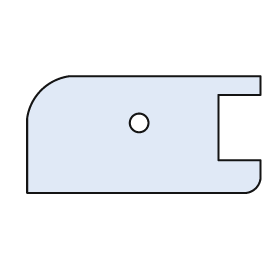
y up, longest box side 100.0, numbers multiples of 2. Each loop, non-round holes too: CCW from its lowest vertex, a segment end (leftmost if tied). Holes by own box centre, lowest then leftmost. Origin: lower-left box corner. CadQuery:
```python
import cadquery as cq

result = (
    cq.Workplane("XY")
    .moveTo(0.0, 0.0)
    .lineTo(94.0, 0.0)
    .threePointArc((98.0, 2.0), (100.0, 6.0))
    .lineTo(100.0, 14.0)
    .lineTo(82.0, 14.0)
    .lineTo(82.0, 42.0)
    .lineTo(100.0, 42.0)
    .lineTo(100.0, 50.0)
    .lineTo(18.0, 50.0)
    .threePointArc((6.0, 44.0), (0.0, 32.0))
    .close()
    .moveTo(48.0, 30.0)
    .circle(4.0)
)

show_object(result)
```